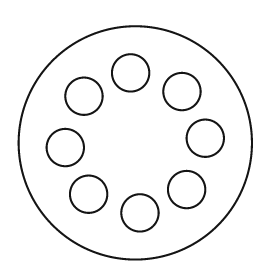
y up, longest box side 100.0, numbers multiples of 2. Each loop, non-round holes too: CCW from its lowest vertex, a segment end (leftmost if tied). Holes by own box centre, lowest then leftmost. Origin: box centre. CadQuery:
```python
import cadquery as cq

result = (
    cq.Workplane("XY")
    .moveTo(0.0, 0.0)
    .circle(50.0)
    .moveTo(2.0, -30.0)
    .circle(8.0)
    .moveTo(-20.0, -22.0)
    .circle(8.0)
    .moveTo(22.0, -20.0)
    .circle(8.0)
    .moveTo(-30.0, -2.0)
    .circle(8.0)
    .moveTo(30.0, 2.0)
    .circle(8.0)
    .moveTo(-22.0, 20.0)
    .circle(8.0)
    .moveTo(20.0, 22.0)
    .circle(8.0)
    .moveTo(-2.0, 30.0)
    .circle(8.0)
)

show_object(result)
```